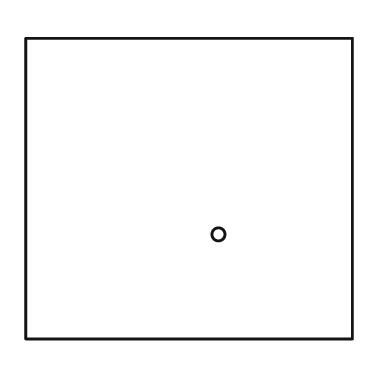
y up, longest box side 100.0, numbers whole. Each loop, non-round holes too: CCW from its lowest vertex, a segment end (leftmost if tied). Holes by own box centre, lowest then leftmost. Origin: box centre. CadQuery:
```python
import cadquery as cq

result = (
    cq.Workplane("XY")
    .moveTo(-50.0, -46.0)
    .lineTo(50.0, -46.0)
    .lineTo(50.0, 46.0)
    .lineTo(-50.0, 46.0)
    .close()
    .moveTo(9.0, -14.0)
    .circle(2.0)
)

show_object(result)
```